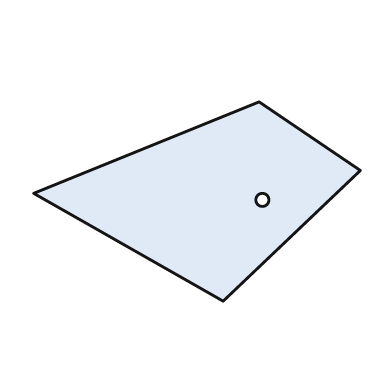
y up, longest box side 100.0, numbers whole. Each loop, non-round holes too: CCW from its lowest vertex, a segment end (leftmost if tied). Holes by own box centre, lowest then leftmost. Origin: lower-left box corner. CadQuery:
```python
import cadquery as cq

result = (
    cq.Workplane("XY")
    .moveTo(58.0, 0.0)
    .lineTo(100.0, 40.0)
    .lineTo(69.0, 61.0)
    .lineTo(0.0, 33.0)
    .close()
    .moveTo(70.0, 31.0)
    .circle(2.0)
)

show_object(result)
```